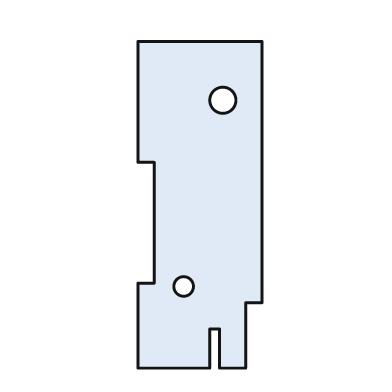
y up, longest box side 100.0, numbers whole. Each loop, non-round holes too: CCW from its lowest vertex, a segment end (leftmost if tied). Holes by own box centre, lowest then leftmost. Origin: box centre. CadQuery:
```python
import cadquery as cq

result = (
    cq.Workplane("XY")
    .moveTo(-19.0, -50.0)
    .lineTo(3.0, -50.0)
    .lineTo(3.0, -38.0)
    .lineTo(6.0, -38.0)
    .lineTo(6.0, -50.0)
    .lineTo(14.0, -50.0)
    .lineTo(14.0, -30.0)
    .lineTo(19.0, -30.0)
    .lineTo(19.0, 50.0)
    .lineTo(-19.0, 50.0)
    .lineTo(-19.0, 13.0)
    .lineTo(-14.0, 13.0)
    .lineTo(-14.0, -24.0)
    .lineTo(-19.0, -24.0)
    .close()
    .moveTo(-5.0, -25.0)
    .circle(3.0)
    .moveTo(7.0, 32.0)
    .circle(4.0)
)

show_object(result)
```